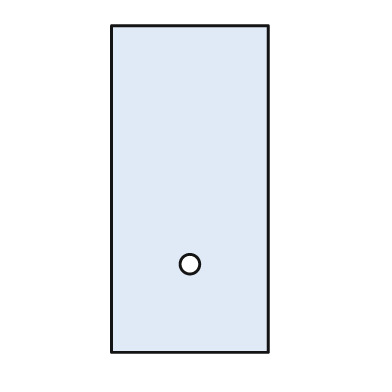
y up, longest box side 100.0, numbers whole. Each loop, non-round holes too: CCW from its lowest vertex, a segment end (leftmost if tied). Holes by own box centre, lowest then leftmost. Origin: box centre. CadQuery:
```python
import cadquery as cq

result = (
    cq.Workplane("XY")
    .moveTo(-24.0, -50.0)
    .lineTo(24.0, -50.0)
    .lineTo(24.0, 50.0)
    .lineTo(-24.0, 50.0)
    .close()
    .moveTo(0.0, -23.0)
    .circle(3.0)
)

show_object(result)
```